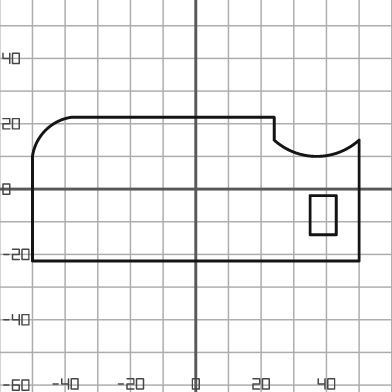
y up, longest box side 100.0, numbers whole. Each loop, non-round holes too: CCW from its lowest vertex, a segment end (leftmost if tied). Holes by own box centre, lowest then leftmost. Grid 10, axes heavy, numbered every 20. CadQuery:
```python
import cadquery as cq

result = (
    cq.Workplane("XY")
    .moveTo(-50.0, -22.0)
    .lineTo(50.0, -22.0)
    .lineTo(50.0, 15.0)
    .threePointArc((37.0, 10.0), (24.0, 15.0))
    .lineTo(24.0, 22.0)
    .lineTo(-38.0, 22.0)
    .threePointArc((-46.0, 18.0), (-50.0, 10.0))
    .close()
    .moveTo(35.0, -14.0)
    .lineTo(43.0, -14.0)
    .lineTo(43.0, -2.0)
    .lineTo(35.0, -2.0)
    .close()
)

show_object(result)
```